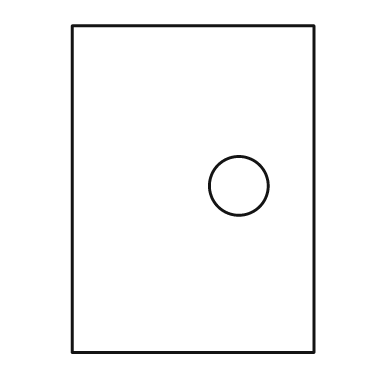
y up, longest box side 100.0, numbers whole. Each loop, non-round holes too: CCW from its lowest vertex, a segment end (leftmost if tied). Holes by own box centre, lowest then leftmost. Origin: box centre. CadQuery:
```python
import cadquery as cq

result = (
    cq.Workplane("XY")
    .moveTo(-37.0, -50.0)
    .lineTo(37.0, -50.0)
    .lineTo(37.0, 50.0)
    .lineTo(-37.0, 50.0)
    .close()
    .moveTo(14.0, 1.0)
    .circle(9.0)
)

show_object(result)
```